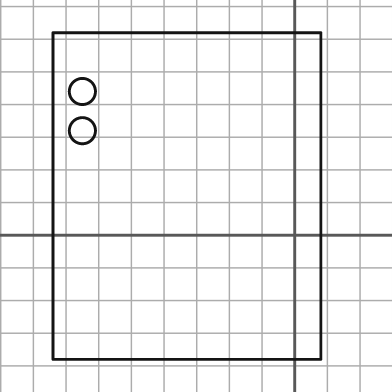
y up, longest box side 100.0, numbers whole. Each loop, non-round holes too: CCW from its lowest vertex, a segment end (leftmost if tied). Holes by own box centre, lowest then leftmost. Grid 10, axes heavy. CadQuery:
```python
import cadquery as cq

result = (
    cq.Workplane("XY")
    .moveTo(-74.0, -38.0)
    .lineTo(8.0, -38.0)
    .lineTo(8.0, 62.0)
    .lineTo(-74.0, 62.0)
    .close()
    .moveTo(-65.0, 32.0)
    .circle(4.0)
    .moveTo(-65.0, 44.0)
    .circle(4.0)
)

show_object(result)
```